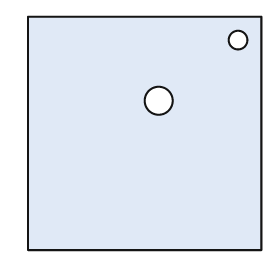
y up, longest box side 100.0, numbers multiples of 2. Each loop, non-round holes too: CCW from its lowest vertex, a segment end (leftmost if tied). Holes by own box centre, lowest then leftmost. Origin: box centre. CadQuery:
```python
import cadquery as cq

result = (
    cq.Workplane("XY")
    .moveTo(-50.0, -50.0)
    .lineTo(50.0, -50.0)
    .lineTo(50.0, 50.0)
    .lineTo(-50.0, 50.0)
    .close()
    .moveTo(6.0, 14.0)
    .circle(6.0)
    .moveTo(40.0, 40.0)
    .circle(4.0)
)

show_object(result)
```